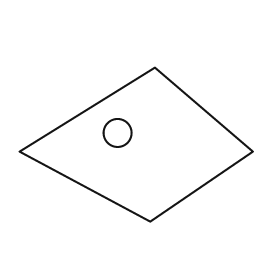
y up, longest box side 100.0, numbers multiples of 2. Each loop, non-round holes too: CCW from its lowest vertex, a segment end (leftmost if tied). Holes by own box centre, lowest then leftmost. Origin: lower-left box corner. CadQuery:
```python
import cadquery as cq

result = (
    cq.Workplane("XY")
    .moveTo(56.0, 0.0)
    .lineTo(100.0, 30.0)
    .lineTo(58.0, 66.0)
    .lineTo(0.0, 30.0)
    .close()
    .moveTo(42.0, 38.0)
    .circle(6.0)
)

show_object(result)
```